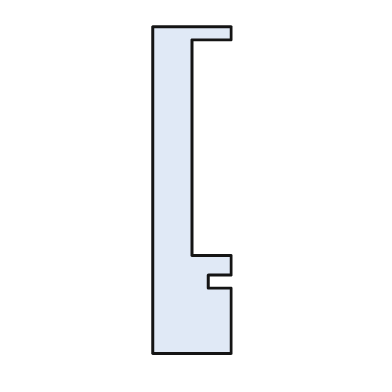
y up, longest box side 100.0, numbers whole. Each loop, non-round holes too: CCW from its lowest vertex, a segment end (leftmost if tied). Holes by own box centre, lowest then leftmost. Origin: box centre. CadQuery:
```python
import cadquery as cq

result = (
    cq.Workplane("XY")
    .moveTo(-12.0, -50.0)
    .lineTo(12.0, -50.0)
    .lineTo(12.0, -30.0)
    .lineTo(5.0, -30.0)
    .lineTo(5.0, -26.0)
    .lineTo(12.0, -26.0)
    .lineTo(12.0, -20.0)
    .lineTo(0.0, -20.0)
    .lineTo(0.0, 46.0)
    .lineTo(12.0, 46.0)
    .lineTo(12.0, 50.0)
    .lineTo(-12.0, 50.0)
    .close()
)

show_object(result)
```